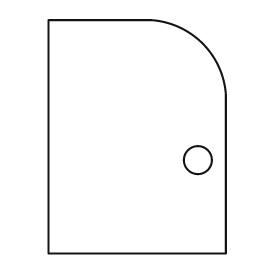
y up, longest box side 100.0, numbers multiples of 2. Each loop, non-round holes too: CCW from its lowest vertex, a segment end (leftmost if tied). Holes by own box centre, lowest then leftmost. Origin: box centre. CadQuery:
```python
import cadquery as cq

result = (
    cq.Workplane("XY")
    .moveTo(-38.0, -50.0)
    .lineTo(38.0, -50.0)
    .lineTo(38.0, 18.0)
    .threePointArc((28.0, 40.0), (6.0, 50.0))
    .lineTo(-38.0, 50.0)
    .close()
    .moveTo(26.0, -10.0)
    .circle(6.0)
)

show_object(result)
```